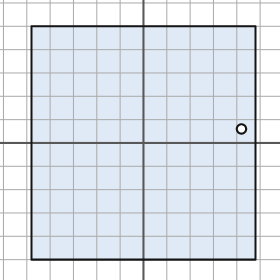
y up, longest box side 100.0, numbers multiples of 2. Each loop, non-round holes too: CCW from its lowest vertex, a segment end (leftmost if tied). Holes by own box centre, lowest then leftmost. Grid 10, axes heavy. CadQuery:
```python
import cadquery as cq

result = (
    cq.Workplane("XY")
    .moveTo(-48.0, -50.0)
    .lineTo(48.0, -50.0)
    .lineTo(48.0, 50.0)
    .lineTo(-48.0, 50.0)
    .close()
    .moveTo(42.0, 6.0)
    .circle(2.0)
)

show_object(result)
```